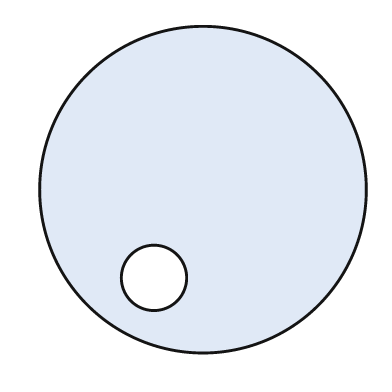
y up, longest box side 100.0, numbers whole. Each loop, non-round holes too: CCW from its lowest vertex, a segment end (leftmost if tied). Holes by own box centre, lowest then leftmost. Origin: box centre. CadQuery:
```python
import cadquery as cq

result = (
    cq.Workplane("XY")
    .moveTo(0.0, 0.0)
    .circle(50.0)
    .moveTo(-15.0, -27.0)
    .circle(10.0)
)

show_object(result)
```